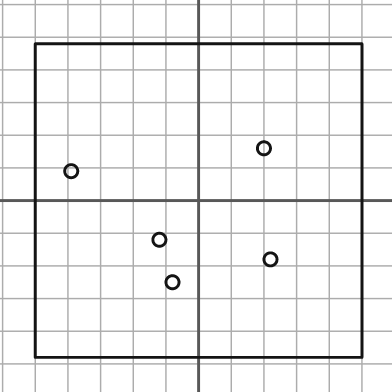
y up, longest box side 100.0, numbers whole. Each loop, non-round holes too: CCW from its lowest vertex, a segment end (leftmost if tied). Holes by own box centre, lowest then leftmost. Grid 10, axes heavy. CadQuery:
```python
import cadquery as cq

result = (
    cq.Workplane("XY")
    .moveTo(-50.0, -48.0)
    .lineTo(50.0, -48.0)
    .lineTo(50.0, 48.0)
    .lineTo(-50.0, 48.0)
    .close()
    .moveTo(-8.0, -25.0)
    .circle(2.0)
    .moveTo(22.0, -18.0)
    .circle(2.0)
    .moveTo(-12.0, -12.0)
    .circle(2.0)
    .moveTo(-39.0, 9.0)
    .circle(2.0)
    .moveTo(20.0, 16.0)
    .circle(2.0)
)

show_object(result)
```